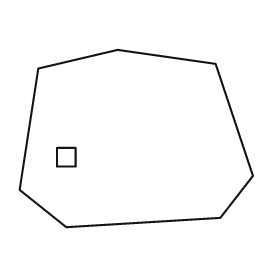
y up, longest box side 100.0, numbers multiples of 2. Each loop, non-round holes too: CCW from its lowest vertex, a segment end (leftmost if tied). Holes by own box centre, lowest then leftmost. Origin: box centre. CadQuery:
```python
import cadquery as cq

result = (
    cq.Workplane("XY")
    .moveTo(-30.0, -38.0)
    .lineTo(36.0, -34.0)
    .lineTo(50.0, -16.0)
    .lineTo(34.0, 32.0)
    .lineTo(-8.0, 38.0)
    .lineTo(-42.0, 30.0)
    .lineTo(-50.0, -22.0)
    .close()
    .moveTo(-34.0, -12.0)
    .lineTo(-26.0, -12.0)
    .lineTo(-26.0, -4.0)
    .lineTo(-34.0, -4.0)
    .close()
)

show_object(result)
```